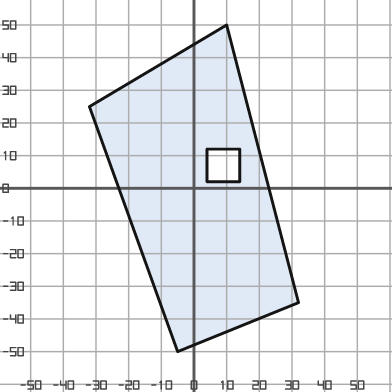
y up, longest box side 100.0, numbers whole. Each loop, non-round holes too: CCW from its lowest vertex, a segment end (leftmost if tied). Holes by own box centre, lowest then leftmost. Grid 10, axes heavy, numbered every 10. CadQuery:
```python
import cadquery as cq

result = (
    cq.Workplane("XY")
    .moveTo(-5.0, -50.0)
    .lineTo(32.0, -35.0)
    .lineTo(10.0, 50.0)
    .lineTo(-32.0, 25.0)
    .close()
    .moveTo(4.0, 2.0)
    .lineTo(14.0, 2.0)
    .lineTo(14.0, 12.0)
    .lineTo(4.0, 12.0)
    .close()
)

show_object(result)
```